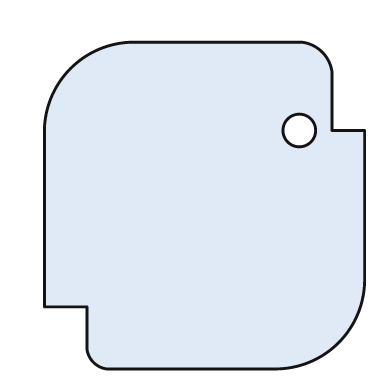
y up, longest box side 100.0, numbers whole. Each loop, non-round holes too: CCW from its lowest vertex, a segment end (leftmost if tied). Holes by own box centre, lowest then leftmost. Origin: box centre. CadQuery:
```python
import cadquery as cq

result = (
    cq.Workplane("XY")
    .moveTo(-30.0, -50.0)
    .lineTo(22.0, -50.0)
    .threePointArc((41.0, -42.0), (49.0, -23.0))
    .lineTo(49.0, 23.0)
    .lineTo(39.0, 23.0)
    .lineTo(39.0, 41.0)
    .threePointArc((36.0, 47.0), (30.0, 50.0))
    .lineTo(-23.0, 50.0)
    .threePointArc((-41.0, 42.0), (-49.0, 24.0))
    .lineTo(-49.0, -31.0)
    .lineTo(-36.0, -31.0)
    .lineTo(-36.0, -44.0)
    .threePointArc((-34.0, -48.0), (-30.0, -50.0))
    .close()
    .moveTo(29.0, 23.0)
    .circle(5.0)
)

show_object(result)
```